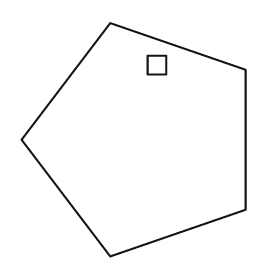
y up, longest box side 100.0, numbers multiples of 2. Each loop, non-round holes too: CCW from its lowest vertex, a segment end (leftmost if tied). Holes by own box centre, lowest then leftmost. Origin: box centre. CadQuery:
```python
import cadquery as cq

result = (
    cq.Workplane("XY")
    .moveTo(-10.0, -50.0)
    .lineTo(48.0, -30.0)
    .lineTo(48.0, 30.0)
    .lineTo(-10.0, 50.0)
    .lineTo(-48.0, 0.0)
    .close()
    .moveTo(6.0, 28.0)
    .lineTo(14.0, 28.0)
    .lineTo(14.0, 36.0)
    .lineTo(6.0, 36.0)
    .close()
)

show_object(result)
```